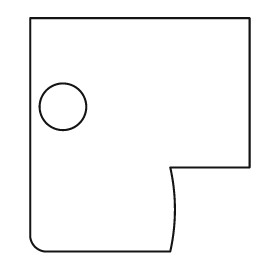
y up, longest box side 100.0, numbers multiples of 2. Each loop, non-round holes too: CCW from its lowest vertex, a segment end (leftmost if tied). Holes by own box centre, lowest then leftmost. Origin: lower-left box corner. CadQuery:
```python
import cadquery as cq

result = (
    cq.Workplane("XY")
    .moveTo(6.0, 0.0)
    .lineTo(60.0, 0.0)
    .threePointArc((62.0, 18.0), (60.0, 36.0))
    .lineTo(94.0, 36.0)
    .lineTo(94.0, 100.0)
    .lineTo(0.0, 100.0)
    .lineTo(0.0, 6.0)
    .threePointArc((2.0, 2.0), (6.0, 0.0))
    .close()
    .moveTo(14.0, 62.0)
    .circle(10.0)
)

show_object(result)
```